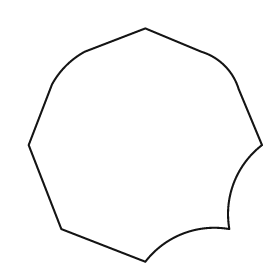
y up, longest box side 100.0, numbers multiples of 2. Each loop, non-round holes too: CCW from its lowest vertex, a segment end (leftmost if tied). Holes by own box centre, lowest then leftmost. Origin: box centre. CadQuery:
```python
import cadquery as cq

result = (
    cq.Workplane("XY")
    .moveTo(0.0, -50.0)
    .threePointArc((16.0, -38.0), (36.0, -36.0))
    .threePointArc((38.0, -16.0), (50.0, 0.0))
    .lineTo(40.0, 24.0)
    .threePointArc((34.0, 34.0), (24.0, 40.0))
    .lineTo(0.0, 50.0)
    .lineTo(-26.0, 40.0)
    .threePointArc((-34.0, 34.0), (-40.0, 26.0))
    .lineTo(-50.0, 0.0)
    .lineTo(-36.0, -36.0)
    .close()
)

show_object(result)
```